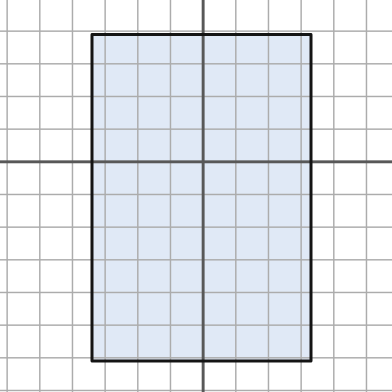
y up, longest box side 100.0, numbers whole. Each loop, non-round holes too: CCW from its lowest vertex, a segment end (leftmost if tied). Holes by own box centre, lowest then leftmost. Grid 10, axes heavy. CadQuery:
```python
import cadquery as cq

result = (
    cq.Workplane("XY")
    .moveTo(-34.0, -61.0)
    .lineTo(33.0, -61.0)
    .lineTo(33.0, 39.0)
    .lineTo(-34.0, 39.0)
    .close()
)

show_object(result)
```